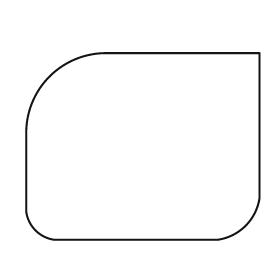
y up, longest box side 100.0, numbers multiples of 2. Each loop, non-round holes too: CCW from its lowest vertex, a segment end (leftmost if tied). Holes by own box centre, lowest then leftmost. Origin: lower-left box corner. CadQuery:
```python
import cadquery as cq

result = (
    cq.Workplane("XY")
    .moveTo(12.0, 0.0)
    .lineTo(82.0, 0.0)
    .threePointArc((94.0, 6.0), (100.0, 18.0))
    .lineTo(100.0, 80.0)
    .lineTo(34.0, 80.0)
    .threePointArc((10.0, 70.0), (0.0, 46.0))
    .lineTo(0.0, 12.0)
    .threePointArc((4.0, 4.0), (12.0, 0.0))
    .close()
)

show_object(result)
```